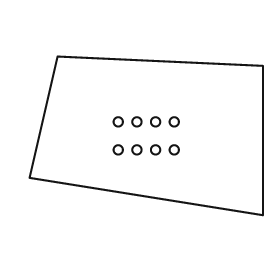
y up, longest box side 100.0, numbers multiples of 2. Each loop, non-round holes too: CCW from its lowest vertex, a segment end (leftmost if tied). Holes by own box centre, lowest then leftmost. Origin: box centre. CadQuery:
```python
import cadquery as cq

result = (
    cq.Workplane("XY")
    .moveTo(50.0, -34.0)
    .lineTo(50.0, 30.0)
    .lineTo(-38.0, 34.0)
    .lineTo(-50.0, -18.0)
    .close()
    .moveTo(-12.0, -6.0)
    .circle(2.0)
    .moveTo(-4.0, -6.0)
    .circle(2.0)
    .moveTo(4.0, -6.0)
    .circle(2.0)
    .moveTo(12.0, -6.0)
    .circle(2.0)
    .moveTo(-12.0, 6.0)
    .circle(2.0)
    .moveTo(-4.0, 6.0)
    .circle(2.0)
    .moveTo(4.0, 6.0)
    .circle(2.0)
    .moveTo(12.0, 6.0)
    .circle(2.0)
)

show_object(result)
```